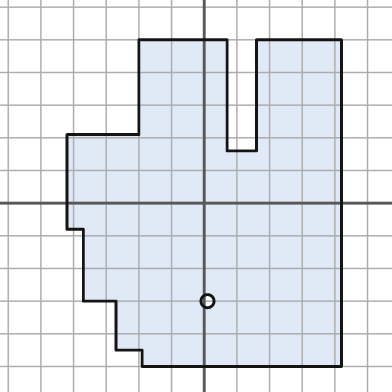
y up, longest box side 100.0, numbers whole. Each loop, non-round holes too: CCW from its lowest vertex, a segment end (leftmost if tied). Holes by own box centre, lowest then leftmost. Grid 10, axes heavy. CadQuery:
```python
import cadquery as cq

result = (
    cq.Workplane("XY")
    .moveTo(-19.0, -50.0)
    .lineTo(42.0, -50.0)
    .lineTo(42.0, 50.0)
    .lineTo(16.0, 50.0)
    .lineTo(16.0, 16.0)
    .lineTo(7.0, 16.0)
    .lineTo(7.0, 50.0)
    .lineTo(-20.0, 50.0)
    .lineTo(-20.0, 21.0)
    .lineTo(-42.0, 21.0)
    .lineTo(-42.0, -8.0)
    .lineTo(-37.0, -8.0)
    .lineTo(-37.0, -30.0)
    .lineTo(-27.0, -30.0)
    .lineTo(-27.0, -45.0)
    .lineTo(-19.0, -45.0)
    .close()
    .moveTo(1.0, -30.0)
    .circle(2.0)
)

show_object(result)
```